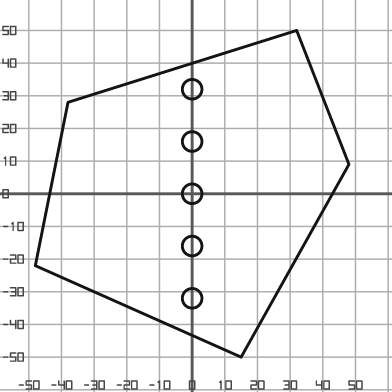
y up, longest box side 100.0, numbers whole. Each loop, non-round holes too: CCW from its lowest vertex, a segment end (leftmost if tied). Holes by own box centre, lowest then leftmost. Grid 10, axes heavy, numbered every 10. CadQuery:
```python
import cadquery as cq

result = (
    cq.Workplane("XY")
    .moveTo(15.0, -50.0)
    .lineTo(48.0, 9.0)
    .lineTo(32.0, 50.0)
    .lineTo(-38.0, 28.0)
    .lineTo(-48.0, -22.0)
    .close()
    .moveTo(0.0, -32.0)
    .circle(3.0)
    .moveTo(0.0, -16.0)
    .circle(3.0)
    .moveTo(0.0, 0.0)
    .circle(3.0)
    .moveTo(0.0, 16.0)
    .circle(3.0)
    .moveTo(0.0, 32.0)
    .circle(3.0)
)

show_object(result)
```